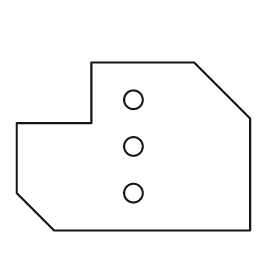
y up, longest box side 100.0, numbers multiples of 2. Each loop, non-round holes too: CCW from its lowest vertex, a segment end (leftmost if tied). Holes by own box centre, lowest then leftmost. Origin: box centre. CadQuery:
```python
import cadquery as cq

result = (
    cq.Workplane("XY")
    .moveTo(-34.0, -36.0)
    .lineTo(50.0, -36.0)
    .lineTo(50.0, 12.0)
    .lineTo(26.0, 36.0)
    .lineTo(-18.0, 36.0)
    .lineTo(-18.0, 10.0)
    .lineTo(-50.0, 10.0)
    .lineTo(-50.0, -20.0)
    .close()
    .moveTo(0.0, -20.0)
    .circle(4.0)
    .moveTo(0.0, 0.0)
    .circle(4.0)
    .moveTo(0.0, 20.0)
    .circle(4.0)
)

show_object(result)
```